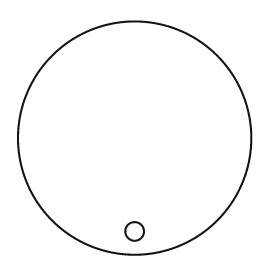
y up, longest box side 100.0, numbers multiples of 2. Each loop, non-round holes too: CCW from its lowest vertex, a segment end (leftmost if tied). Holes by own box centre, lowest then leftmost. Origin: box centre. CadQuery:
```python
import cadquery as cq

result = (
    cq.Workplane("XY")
    .moveTo(0.0, 0.0)
    .circle(50.0)
    .moveTo(0.0, -40.0)
    .circle(4.0)
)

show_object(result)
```